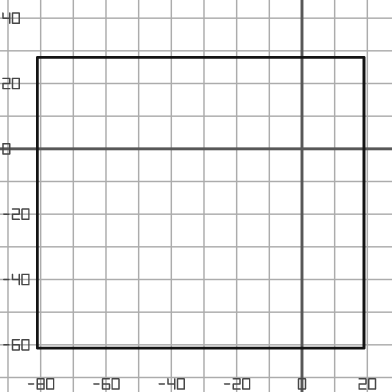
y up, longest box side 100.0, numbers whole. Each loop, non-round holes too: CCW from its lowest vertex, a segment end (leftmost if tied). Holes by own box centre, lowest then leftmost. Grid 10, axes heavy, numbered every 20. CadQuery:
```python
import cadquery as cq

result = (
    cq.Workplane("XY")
    .moveTo(-81.0, -61.0)
    .lineTo(19.0, -61.0)
    .lineTo(19.0, 28.0)
    .lineTo(-81.0, 28.0)
    .close()
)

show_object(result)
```